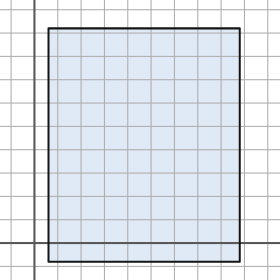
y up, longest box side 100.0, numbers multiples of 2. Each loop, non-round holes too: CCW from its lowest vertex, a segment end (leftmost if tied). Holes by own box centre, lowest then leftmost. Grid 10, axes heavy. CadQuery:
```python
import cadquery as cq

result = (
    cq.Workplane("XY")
    .moveTo(6.0, -8.0)
    .lineTo(88.0, -8.0)
    .lineTo(88.0, 92.0)
    .lineTo(6.0, 92.0)
    .close()
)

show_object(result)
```